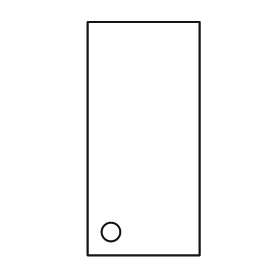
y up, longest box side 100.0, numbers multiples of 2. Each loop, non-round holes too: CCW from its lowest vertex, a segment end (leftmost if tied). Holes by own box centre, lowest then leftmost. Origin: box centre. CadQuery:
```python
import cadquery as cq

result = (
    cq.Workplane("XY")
    .moveTo(-24.0, -50.0)
    .lineTo(24.0, -50.0)
    .lineTo(24.0, 50.0)
    .lineTo(-24.0, 50.0)
    .close()
    .moveTo(-14.0, -40.0)
    .circle(4.0)
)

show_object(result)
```